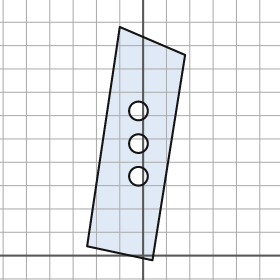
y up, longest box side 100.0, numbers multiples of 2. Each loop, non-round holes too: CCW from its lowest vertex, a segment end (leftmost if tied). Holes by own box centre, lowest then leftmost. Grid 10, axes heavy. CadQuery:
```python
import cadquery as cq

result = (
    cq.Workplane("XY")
    .moveTo(4.0, -2.0)
    .lineTo(18.0, 86.0)
    .lineTo(-10.0, 98.0)
    .lineTo(-24.0, 4.0)
    .close()
    .moveTo(-2.0, 34.0)
    .circle(4.0)
    .moveTo(-2.0, 48.0)
    .circle(4.0)
    .moveTo(-2.0, 62.0)
    .circle(4.0)
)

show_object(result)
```